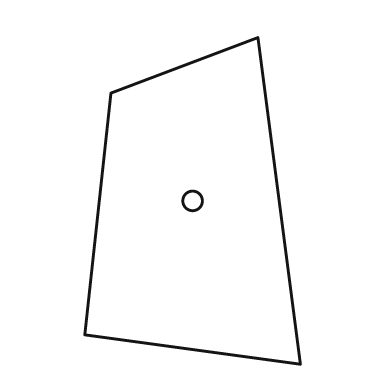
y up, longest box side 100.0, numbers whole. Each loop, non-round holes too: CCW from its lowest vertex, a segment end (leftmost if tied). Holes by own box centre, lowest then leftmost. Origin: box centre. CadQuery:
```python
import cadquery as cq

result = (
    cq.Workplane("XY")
    .moveTo(33.0, -50.0)
    .lineTo(20.0, 50.0)
    .lineTo(-25.0, 33.0)
    .lineTo(-33.0, -41.0)
    .close()
    .moveTo(0.0, 0.0)
    .circle(3.0)
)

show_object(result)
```